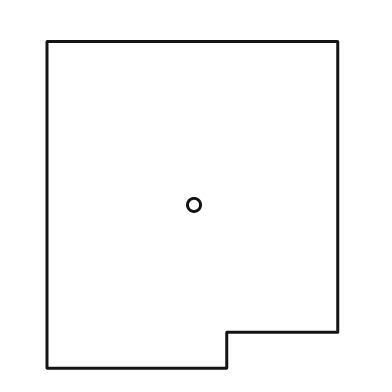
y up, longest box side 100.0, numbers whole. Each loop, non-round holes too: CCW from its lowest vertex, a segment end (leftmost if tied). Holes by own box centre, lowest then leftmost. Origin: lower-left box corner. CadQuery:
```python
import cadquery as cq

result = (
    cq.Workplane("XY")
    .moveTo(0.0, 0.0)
    .lineTo(55.0, 0.0)
    .lineTo(55.0, 11.0)
    .lineTo(89.0, 11.0)
    .lineTo(89.0, 100.0)
    .lineTo(0.0, 100.0)
    .close()
    .moveTo(45.0, 50.0)
    .circle(2.0)
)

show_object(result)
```